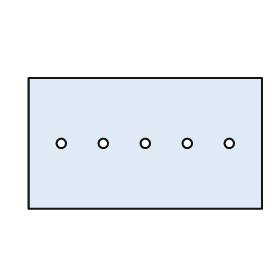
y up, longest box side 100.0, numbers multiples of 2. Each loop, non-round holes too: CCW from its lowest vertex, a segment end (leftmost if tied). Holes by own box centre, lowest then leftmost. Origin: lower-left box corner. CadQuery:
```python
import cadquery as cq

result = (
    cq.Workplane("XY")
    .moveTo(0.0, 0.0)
    .lineTo(100.0, 0.0)
    .lineTo(100.0, 56.0)
    .lineTo(0.0, 56.0)
    .close()
    .moveTo(14.0, 28.0)
    .circle(2.0)
    .moveTo(32.0, 28.0)
    .circle(2.0)
    .moveTo(50.0, 28.0)
    .circle(2.0)
    .moveTo(68.0, 28.0)
    .circle(2.0)
    .moveTo(86.0, 28.0)
    .circle(2.0)
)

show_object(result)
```